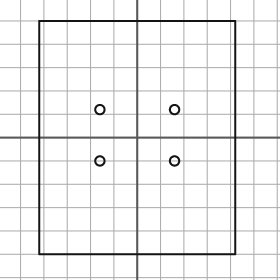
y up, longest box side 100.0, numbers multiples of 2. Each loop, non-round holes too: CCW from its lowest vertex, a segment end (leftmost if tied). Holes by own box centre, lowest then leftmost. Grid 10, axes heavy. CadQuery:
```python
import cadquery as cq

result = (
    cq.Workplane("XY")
    .moveTo(-42.0, -50.0)
    .lineTo(42.0, -50.0)
    .lineTo(42.0, 50.0)
    .lineTo(-42.0, 50.0)
    .close()
    .moveTo(-16.0, -10.0)
    .circle(2.0)
    .moveTo(16.0, -10.0)
    .circle(2.0)
    .moveTo(-16.0, 12.0)
    .circle(2.0)
    .moveTo(16.0, 12.0)
    .circle(2.0)
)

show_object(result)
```